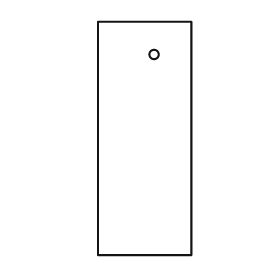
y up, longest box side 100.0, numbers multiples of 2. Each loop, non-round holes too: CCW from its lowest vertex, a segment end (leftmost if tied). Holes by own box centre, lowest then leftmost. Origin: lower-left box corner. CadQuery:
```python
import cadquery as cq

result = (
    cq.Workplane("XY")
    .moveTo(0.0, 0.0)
    .lineTo(40.0, 0.0)
    .lineTo(40.0, 100.0)
    .lineTo(0.0, 100.0)
    .close()
    .moveTo(24.0, 86.0)
    .circle(2.0)
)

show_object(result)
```